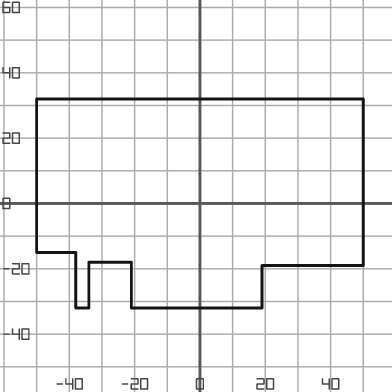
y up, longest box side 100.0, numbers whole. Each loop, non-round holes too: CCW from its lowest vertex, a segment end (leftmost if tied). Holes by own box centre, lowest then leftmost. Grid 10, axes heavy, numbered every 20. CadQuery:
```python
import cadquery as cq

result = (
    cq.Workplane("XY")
    .moveTo(-38.0, -32.0)
    .lineTo(-34.0, -32.0)
    .lineTo(-34.0, -18.0)
    .lineTo(-21.0, -18.0)
    .lineTo(-21.0, -32.0)
    .lineTo(19.0, -32.0)
    .lineTo(19.0, -19.0)
    .lineTo(50.0, -19.0)
    .lineTo(50.0, 32.0)
    .lineTo(-50.0, 32.0)
    .lineTo(-50.0, -15.0)
    .lineTo(-38.0, -15.0)
    .close()
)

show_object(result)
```